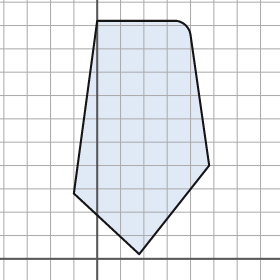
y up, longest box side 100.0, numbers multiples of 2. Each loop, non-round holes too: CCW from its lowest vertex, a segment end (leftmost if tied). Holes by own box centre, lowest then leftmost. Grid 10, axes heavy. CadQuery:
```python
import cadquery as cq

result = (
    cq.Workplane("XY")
    .moveTo(18.0, 2.0)
    .lineTo(48.0, 40.0)
    .lineTo(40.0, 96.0)
    .threePointArc((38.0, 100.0), (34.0, 102.0))
    .lineTo(0.0, 102.0)
    .lineTo(-10.0, 28.0)
    .close()
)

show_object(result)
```